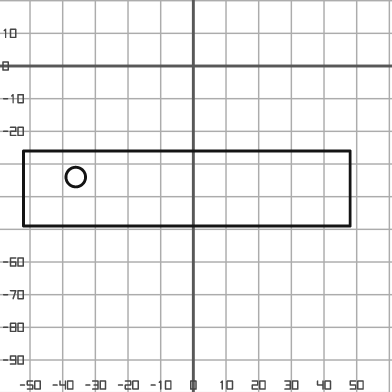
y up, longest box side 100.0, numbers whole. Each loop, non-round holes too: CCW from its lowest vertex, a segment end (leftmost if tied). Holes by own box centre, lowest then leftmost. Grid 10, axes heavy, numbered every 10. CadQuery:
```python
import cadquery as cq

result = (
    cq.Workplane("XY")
    .moveTo(-52.0, -49.0)
    .lineTo(48.0, -49.0)
    .lineTo(48.0, -26.0)
    .lineTo(-52.0, -26.0)
    .close()
    .moveTo(-36.0, -34.0)
    .circle(3.0)
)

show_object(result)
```